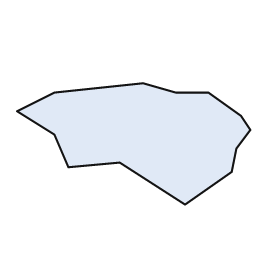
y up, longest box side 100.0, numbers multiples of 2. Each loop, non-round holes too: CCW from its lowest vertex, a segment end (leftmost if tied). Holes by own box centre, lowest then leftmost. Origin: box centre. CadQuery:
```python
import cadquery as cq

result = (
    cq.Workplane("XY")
    .moveTo(22.0, -26.0)
    .lineTo(42.0, -12.0)
    .lineTo(44.0, -2.0)
    .lineTo(50.0, 6.0)
    .lineTo(46.0, 12.0)
    .lineTo(32.0, 22.0)
    .lineTo(18.0, 22.0)
    .lineTo(4.0, 26.0)
    .lineTo(-34.0, 22.0)
    .lineTo(-50.0, 14.0)
    .lineTo(-34.0, 4.0)
    .lineTo(-28.0, -10.0)
    .lineTo(-6.0, -8.0)
    .close()
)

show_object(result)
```